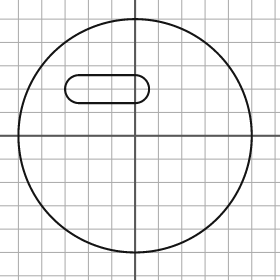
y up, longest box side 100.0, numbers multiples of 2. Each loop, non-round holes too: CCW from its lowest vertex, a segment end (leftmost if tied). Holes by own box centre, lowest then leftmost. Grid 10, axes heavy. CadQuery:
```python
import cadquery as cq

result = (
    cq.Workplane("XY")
    .moveTo(0.0, 0.0)
    .circle(50.0)
    .moveTo(-24.0, 14.0)
    .lineTo(0.0, 14.0)
    .threePointArc((6.0, 20.0), (0.0, 26.0))
    .lineTo(-24.0, 26.0)
    .threePointArc((-30.0, 20.0), (-24.0, 14.0))
    .close()
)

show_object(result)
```